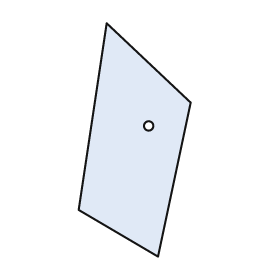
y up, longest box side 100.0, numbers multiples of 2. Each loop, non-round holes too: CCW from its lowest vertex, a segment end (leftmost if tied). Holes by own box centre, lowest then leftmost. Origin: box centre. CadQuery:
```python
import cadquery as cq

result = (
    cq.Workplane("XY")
    .moveTo(10.0, -50.0)
    .lineTo(24.0, 16.0)
    .lineTo(-12.0, 50.0)
    .lineTo(-24.0, -30.0)
    .close()
    .moveTo(6.0, 6.0)
    .circle(2.0)
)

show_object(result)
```